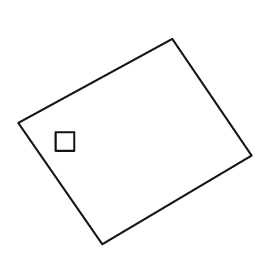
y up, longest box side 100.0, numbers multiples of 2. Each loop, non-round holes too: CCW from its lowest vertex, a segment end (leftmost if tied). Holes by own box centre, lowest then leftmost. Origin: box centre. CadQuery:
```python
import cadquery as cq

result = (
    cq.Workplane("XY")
    .moveTo(-14.0, -44.0)
    .lineTo(50.0, -6.0)
    .lineTo(16.0, 44.0)
    .lineTo(-50.0, 8.0)
    .close()
    .moveTo(-34.0, -4.0)
    .lineTo(-26.0, -4.0)
    .lineTo(-26.0, 4.0)
    .lineTo(-34.0, 4.0)
    .close()
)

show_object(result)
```